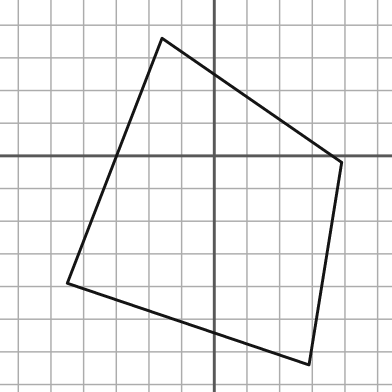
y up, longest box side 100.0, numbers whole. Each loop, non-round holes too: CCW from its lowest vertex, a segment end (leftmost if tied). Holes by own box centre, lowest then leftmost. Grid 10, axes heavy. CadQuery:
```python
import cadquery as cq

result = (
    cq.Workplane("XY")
    .moveTo(29.0, -64.0)
    .lineTo(39.0, -2.0)
    .lineTo(-16.0, 36.0)
    .lineTo(-45.0, -39.0)
    .close()
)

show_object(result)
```